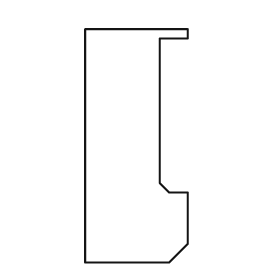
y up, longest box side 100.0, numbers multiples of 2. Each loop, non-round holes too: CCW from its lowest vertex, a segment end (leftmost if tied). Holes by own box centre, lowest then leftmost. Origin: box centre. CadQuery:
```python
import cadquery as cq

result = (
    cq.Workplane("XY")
    .moveTo(-22.0, -50.0)
    .lineTo(14.0, -50.0)
    .lineTo(22.0, -42.0)
    .lineTo(22.0, -20.0)
    .lineTo(14.0, -20.0)
    .lineTo(10.0, -16.0)
    .lineTo(10.0, 46.0)
    .lineTo(22.0, 46.0)
    .lineTo(22.0, 50.0)
    .lineTo(-22.0, 50.0)
    .close()
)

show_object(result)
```